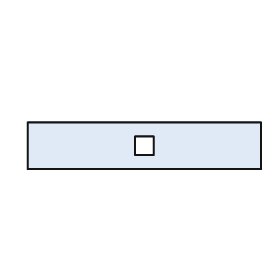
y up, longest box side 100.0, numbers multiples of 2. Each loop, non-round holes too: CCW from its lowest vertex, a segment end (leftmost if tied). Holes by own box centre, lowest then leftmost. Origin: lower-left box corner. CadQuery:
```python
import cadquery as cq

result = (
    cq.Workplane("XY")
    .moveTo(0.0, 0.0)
    .lineTo(100.0, 0.0)
    .lineTo(100.0, 20.0)
    .lineTo(0.0, 20.0)
    .close()
    .moveTo(46.0, 6.0)
    .lineTo(54.0, 6.0)
    .lineTo(54.0, 14.0)
    .lineTo(46.0, 14.0)
    .close()
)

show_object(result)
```